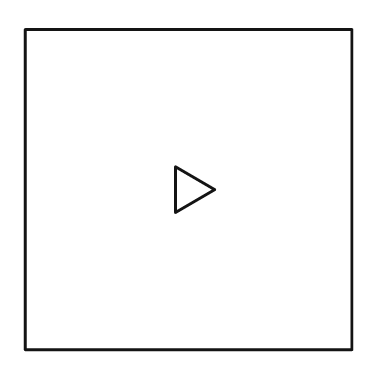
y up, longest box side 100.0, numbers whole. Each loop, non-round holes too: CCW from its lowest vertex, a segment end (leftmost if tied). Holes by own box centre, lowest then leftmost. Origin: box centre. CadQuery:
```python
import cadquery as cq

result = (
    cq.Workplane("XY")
    .moveTo(-50.0, -49.0)
    .lineTo(50.0, -49.0)
    .lineTo(50.0, 49.0)
    .lineTo(-50.0, 49.0)
    .close()
    .moveTo(-4.0, -7.0)
    .lineTo(8.0, 0.0)
    .lineTo(-4.0, 7.0)
    .close()
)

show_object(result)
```